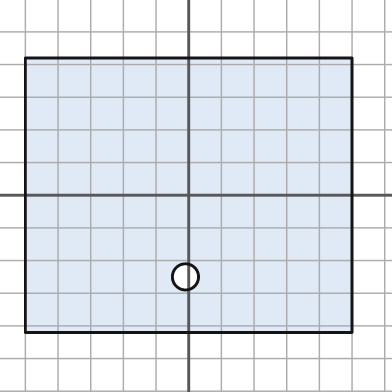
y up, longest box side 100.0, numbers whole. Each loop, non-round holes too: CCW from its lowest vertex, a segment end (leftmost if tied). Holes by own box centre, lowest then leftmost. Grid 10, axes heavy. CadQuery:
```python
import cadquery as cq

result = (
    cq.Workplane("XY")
    .moveTo(-50.0, -42.0)
    .lineTo(50.0, -42.0)
    .lineTo(50.0, 42.0)
    .lineTo(-50.0, 42.0)
    .close()
    .moveTo(-1.0, -25.0)
    .circle(4.0)
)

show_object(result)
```